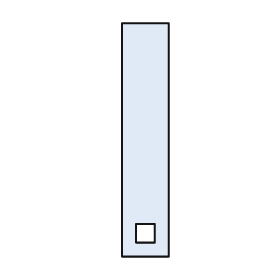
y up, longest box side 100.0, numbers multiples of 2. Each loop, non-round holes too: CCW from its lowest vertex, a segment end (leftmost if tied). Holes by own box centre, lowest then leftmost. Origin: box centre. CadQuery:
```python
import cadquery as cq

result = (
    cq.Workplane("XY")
    .moveTo(-10.0, -50.0)
    .lineTo(10.0, -50.0)
    .lineTo(10.0, 50.0)
    .lineTo(-10.0, 50.0)
    .close()
    .moveTo(-4.0, -44.0)
    .lineTo(4.0, -44.0)
    .lineTo(4.0, -36.0)
    .lineTo(-4.0, -36.0)
    .close()
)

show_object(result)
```